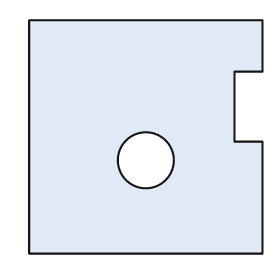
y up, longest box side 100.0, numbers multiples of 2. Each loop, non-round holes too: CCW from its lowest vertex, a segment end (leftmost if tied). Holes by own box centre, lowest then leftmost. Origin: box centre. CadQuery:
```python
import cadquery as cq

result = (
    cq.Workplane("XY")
    .moveTo(-50.0, -50.0)
    .lineTo(50.0, -50.0)
    .lineTo(50.0, -2.0)
    .lineTo(38.0, -2.0)
    .lineTo(38.0, 28.0)
    .lineTo(50.0, 28.0)
    .lineTo(50.0, 50.0)
    .lineTo(-50.0, 50.0)
    .close()
    .moveTo(0.0, -10.0)
    .circle(12.0)
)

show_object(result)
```